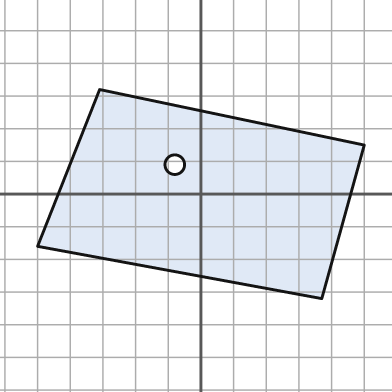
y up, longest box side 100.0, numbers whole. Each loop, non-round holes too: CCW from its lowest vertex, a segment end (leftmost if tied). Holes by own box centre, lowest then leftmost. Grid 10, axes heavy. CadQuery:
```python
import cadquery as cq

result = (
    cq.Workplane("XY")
    .moveTo(37.0, -32.0)
    .lineTo(50.0, 15.0)
    .lineTo(-31.0, 32.0)
    .lineTo(-50.0, -16.0)
    .close()
    .moveTo(-8.0, 9.0)
    .circle(3.0)
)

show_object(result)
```